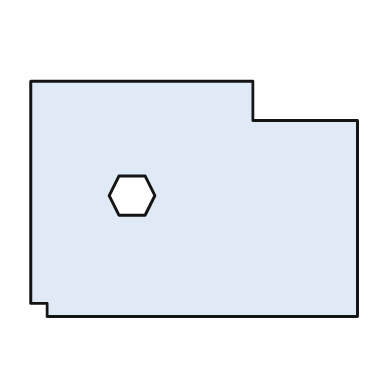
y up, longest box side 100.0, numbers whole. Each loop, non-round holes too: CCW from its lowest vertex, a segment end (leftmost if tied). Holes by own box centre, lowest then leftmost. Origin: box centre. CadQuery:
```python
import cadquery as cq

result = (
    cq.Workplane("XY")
    .moveTo(-45.0, -36.0)
    .lineTo(50.0, -36.0)
    .lineTo(50.0, 24.0)
    .lineTo(18.0, 24.0)
    .lineTo(18.0, 36.0)
    .lineTo(-50.0, 36.0)
    .lineTo(-50.0, -32.0)
    .lineTo(-45.0, -32.0)
    .close()
    .moveTo(-23.0, -5.0)
    .lineTo(-15.0, -5.0)
    .lineTo(-12.0, 1.0)
    .lineTo(-15.0, 7.0)
    .lineTo(-23.0, 7.0)
    .lineTo(-26.0, 1.0)
    .close()
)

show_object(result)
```